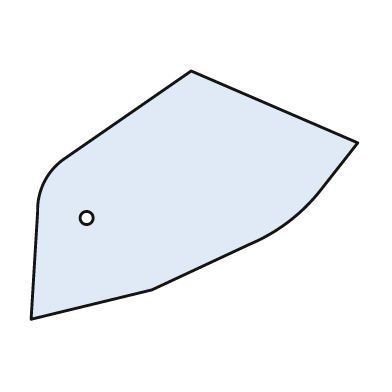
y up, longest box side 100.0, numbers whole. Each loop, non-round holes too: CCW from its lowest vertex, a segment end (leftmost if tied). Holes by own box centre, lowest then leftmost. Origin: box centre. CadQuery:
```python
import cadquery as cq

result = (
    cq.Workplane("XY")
    .moveTo(-50.0, -38.0)
    .lineTo(-13.0, -29.0)
    .lineTo(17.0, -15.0)
    .threePointArc((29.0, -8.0), (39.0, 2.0))
    .lineTo(50.0, 16.0)
    .lineTo(-1.0, 38.0)
    .lineTo(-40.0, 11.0)
    .threePointArc((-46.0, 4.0), (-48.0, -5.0))
    .close()
    .moveTo(-33.0, -7.0)
    .circle(2.0)
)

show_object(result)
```